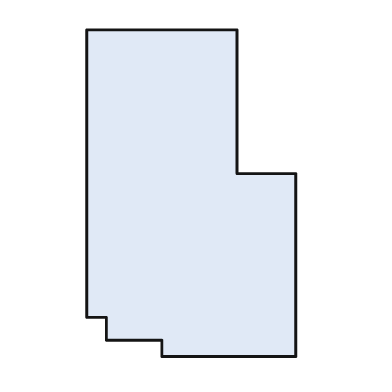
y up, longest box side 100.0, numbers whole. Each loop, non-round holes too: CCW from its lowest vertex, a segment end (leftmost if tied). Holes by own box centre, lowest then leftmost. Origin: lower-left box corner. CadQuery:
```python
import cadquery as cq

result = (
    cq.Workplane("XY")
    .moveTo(23.0, 0.0)
    .lineTo(64.0, 0.0)
    .lineTo(64.0, 56.0)
    .lineTo(46.0, 56.0)
    .lineTo(46.0, 100.0)
    .lineTo(0.0, 100.0)
    .lineTo(0.0, 12.0)
    .lineTo(6.0, 12.0)
    .lineTo(6.0, 5.0)
    .lineTo(23.0, 5.0)
    .close()
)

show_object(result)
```